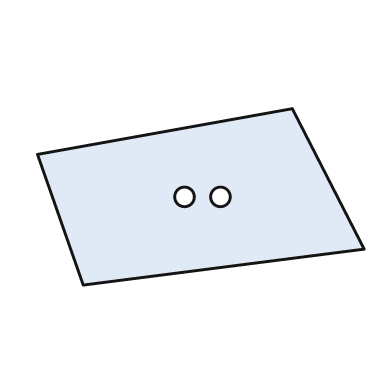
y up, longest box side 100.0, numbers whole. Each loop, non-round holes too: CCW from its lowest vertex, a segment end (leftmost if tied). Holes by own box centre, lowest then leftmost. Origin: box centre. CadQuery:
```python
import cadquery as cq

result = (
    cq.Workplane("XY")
    .moveTo(-36.0, -27.0)
    .lineTo(50.0, -16.0)
    .lineTo(28.0, 27.0)
    .lineTo(-50.0, 13.0)
    .close()
    .moveTo(-5.0, 0.0)
    .circle(3.0)
    .moveTo(6.0, 0.0)
    .circle(3.0)
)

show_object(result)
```